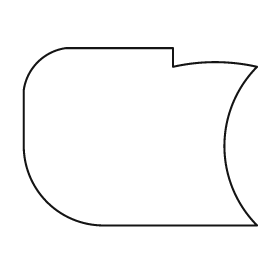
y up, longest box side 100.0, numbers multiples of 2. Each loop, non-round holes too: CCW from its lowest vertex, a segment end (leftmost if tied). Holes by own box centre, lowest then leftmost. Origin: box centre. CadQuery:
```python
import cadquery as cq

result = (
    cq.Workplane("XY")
    .moveTo(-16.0, -38.0)
    .lineTo(50.0, -38.0)
    .threePointArc((36.0, -4.0), (50.0, 30.0))
    .threePointArc((32.0, 32.0), (14.0, 30.0))
    .lineTo(14.0, 38.0)
    .lineTo(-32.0, 38.0)
    .threePointArc((-44.0, 32.0), (-50.0, 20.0))
    .lineTo(-50.0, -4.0)
    .threePointArc((-40.0, -28.0), (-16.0, -38.0))
    .close()
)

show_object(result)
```